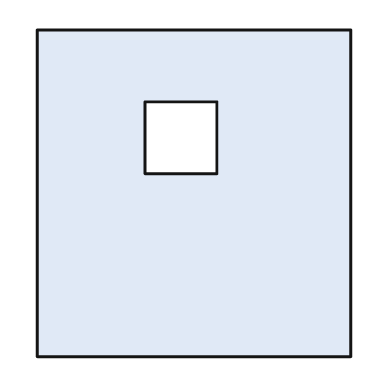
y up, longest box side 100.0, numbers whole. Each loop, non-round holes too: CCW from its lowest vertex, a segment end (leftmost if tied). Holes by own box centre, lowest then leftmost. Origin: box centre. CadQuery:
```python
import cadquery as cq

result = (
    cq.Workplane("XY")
    .moveTo(-48.0, -50.0)
    .lineTo(48.0, -50.0)
    .lineTo(48.0, 50.0)
    .lineTo(-48.0, 50.0)
    .close()
    .moveTo(-15.0, 6.0)
    .lineTo(7.0, 6.0)
    .lineTo(7.0, 28.0)
    .lineTo(-15.0, 28.0)
    .close()
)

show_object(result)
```